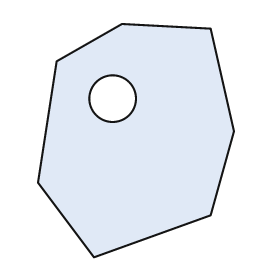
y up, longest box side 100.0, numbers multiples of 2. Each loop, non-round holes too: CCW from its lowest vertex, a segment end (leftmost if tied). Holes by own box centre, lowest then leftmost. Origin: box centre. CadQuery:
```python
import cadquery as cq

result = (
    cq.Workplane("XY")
    .moveTo(-18.0, -50.0)
    .lineTo(32.0, -32.0)
    .lineTo(42.0, 4.0)
    .lineTo(32.0, 48.0)
    .lineTo(-6.0, 50.0)
    .lineTo(-34.0, 34.0)
    .lineTo(-42.0, -18.0)
    .close()
    .moveTo(-10.0, 18.0)
    .circle(10.0)
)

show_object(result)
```